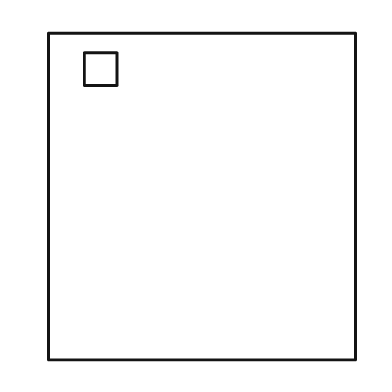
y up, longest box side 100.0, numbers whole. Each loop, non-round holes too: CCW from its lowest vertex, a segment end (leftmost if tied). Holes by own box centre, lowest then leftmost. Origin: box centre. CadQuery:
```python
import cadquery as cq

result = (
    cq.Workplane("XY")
    .moveTo(-47.0, -50.0)
    .lineTo(47.0, -50.0)
    .lineTo(47.0, 50.0)
    .lineTo(-47.0, 50.0)
    .close()
    .moveTo(-36.0, 34.0)
    .lineTo(-26.0, 34.0)
    .lineTo(-26.0, 44.0)
    .lineTo(-36.0, 44.0)
    .close()
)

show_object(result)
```